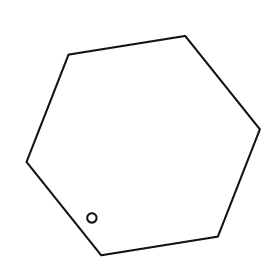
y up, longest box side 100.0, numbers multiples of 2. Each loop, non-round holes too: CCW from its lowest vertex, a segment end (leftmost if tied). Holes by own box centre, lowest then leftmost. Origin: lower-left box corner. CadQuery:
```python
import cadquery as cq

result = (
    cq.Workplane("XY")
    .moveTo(32.0, 0.0)
    .lineTo(82.0, 8.0)
    .lineTo(100.0, 54.0)
    .lineTo(68.0, 94.0)
    .lineTo(18.0, 86.0)
    .lineTo(0.0, 40.0)
    .close()
    .moveTo(28.0, 16.0)
    .circle(2.0)
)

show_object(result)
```